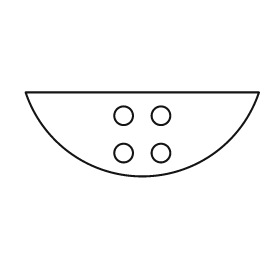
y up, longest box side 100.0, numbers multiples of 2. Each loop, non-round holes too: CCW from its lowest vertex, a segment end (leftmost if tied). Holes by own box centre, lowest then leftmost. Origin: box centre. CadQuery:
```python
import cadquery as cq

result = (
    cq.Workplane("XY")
    .moveTo(-50.0, 18.0)
    .threePointArc((0.0, -18.0), (50.0, 18.0))
    .close()
    .moveTo(-8.0, -8.0)
    .circle(4.0)
    .moveTo(8.0, -8.0)
    .circle(4.0)
    .moveTo(-8.0, 8.0)
    .circle(4.0)
    .moveTo(8.0, 8.0)
    .circle(4.0)
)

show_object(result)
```